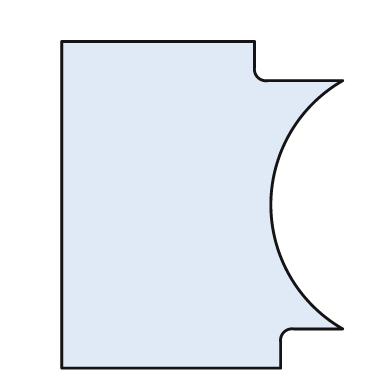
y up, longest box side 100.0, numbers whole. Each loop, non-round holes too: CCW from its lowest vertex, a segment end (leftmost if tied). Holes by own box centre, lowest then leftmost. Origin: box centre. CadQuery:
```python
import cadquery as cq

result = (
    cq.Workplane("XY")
    .moveTo(-43.0, -50.0)
    .lineTo(24.0, -50.0)
    .lineTo(24.0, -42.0)
    .threePointArc((25.0, -39.0), (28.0, -38.0))
    .lineTo(43.0, -38.0)
    .threePointArc((21.0, 0.0), (43.0, 38.0))
    .lineTo(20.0, 38.0)
    .threePointArc((17.0, 39.0), (16.0, 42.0))
    .lineTo(16.0, 50.0)
    .lineTo(-43.0, 50.0)
    .close()
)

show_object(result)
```